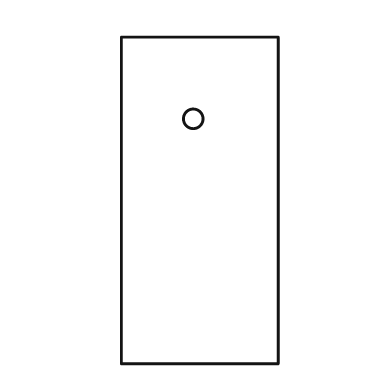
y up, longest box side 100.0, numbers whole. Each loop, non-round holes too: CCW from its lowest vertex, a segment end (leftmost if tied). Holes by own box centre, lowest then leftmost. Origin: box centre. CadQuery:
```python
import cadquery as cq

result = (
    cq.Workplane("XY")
    .moveTo(-24.0, -50.0)
    .lineTo(24.0, -50.0)
    .lineTo(24.0, 50.0)
    .lineTo(-24.0, 50.0)
    .close()
    .moveTo(-2.0, 25.0)
    .circle(3.0)
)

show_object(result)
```